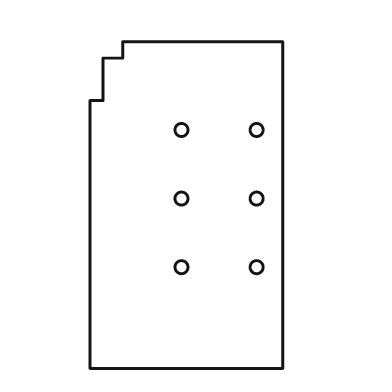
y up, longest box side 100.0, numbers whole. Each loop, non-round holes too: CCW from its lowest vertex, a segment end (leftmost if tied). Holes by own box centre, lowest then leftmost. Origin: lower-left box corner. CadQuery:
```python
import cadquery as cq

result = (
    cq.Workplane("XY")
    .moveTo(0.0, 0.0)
    .lineTo(59.0, 0.0)
    .lineTo(59.0, 100.0)
    .lineTo(10.0, 100.0)
    .lineTo(10.0, 95.0)
    .lineTo(4.0, 95.0)
    .lineTo(4.0, 82.0)
    .lineTo(0.0, 82.0)
    .close()
    .moveTo(28.0, 31.0)
    .circle(2.0)
    .moveTo(51.0, 31.0)
    .circle(2.0)
    .moveTo(28.0, 52.0)
    .circle(2.0)
    .moveTo(51.0, 52.0)
    .circle(2.0)
    .moveTo(28.0, 73.0)
    .circle(2.0)
    .moveTo(51.0, 73.0)
    .circle(2.0)
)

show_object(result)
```